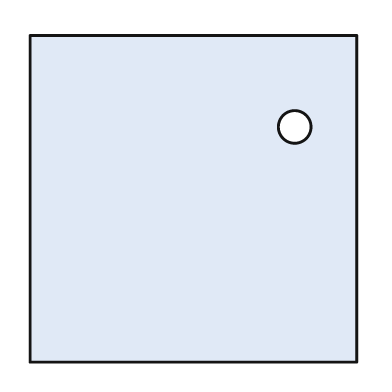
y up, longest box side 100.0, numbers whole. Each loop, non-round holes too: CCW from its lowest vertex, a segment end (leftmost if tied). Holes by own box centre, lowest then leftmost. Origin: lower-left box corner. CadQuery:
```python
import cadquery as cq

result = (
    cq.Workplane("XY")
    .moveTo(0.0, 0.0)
    .lineTo(100.0, 0.0)
    .lineTo(100.0, 100.0)
    .lineTo(0.0, 100.0)
    .close()
    .moveTo(81.0, 72.0)
    .circle(5.0)
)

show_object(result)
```